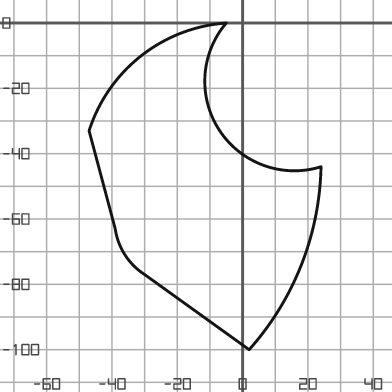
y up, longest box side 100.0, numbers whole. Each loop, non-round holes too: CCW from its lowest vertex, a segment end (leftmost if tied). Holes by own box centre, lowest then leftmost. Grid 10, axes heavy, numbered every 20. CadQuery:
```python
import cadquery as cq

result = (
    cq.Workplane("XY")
    .moveTo(2.0, -100.0)
    .threePointArc((18.0, -74.0), (24.0, -44.0))
    .threePointArc((-7.0, -33.0), (-5.0, 0.0))
    .threePointArc((-31.0, -10.0), (-47.0, -33.0))
    .lineTo(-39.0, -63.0)
    .threePointArc((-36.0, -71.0), (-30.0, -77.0))
    .close()
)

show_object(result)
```